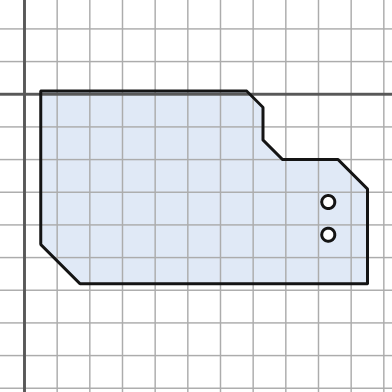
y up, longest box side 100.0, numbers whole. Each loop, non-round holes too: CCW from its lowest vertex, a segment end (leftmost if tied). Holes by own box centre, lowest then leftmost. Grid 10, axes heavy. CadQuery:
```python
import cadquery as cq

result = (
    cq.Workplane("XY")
    .moveTo(17.0, -58.0)
    .lineTo(105.0, -58.0)
    .lineTo(105.0, -29.0)
    .lineTo(96.0, -20.0)
    .lineTo(79.0, -20.0)
    .lineTo(73.0, -14.0)
    .lineTo(73.0, -4.0)
    .lineTo(68.0, 1.0)
    .lineTo(5.0, 1.0)
    .lineTo(5.0, -46.0)
    .close()
    .moveTo(93.0, -43.0)
    .circle(2.0)
    .moveTo(93.0, -33.0)
    .circle(2.0)
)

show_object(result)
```